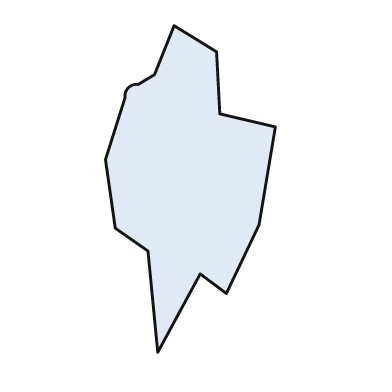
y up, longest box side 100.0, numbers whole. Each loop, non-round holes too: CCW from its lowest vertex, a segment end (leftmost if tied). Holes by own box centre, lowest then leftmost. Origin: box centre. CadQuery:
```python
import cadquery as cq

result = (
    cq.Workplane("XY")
    .moveTo(-10.0, -50.0)
    .lineTo(3.0, -26.0)
    .lineTo(11.0, -32.0)
    .lineTo(21.0, -11.0)
    .lineTo(26.0, 19.0)
    .lineTo(9.0, 23.0)
    .lineTo(8.0, 42.0)
    .lineTo(-5.0, 50.0)
    .lineTo(-11.0, 35.0)
    .lineTo(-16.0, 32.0)
    .threePointArc((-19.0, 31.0), (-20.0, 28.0))
    .lineTo(-26.0, 9.0)
    .lineTo(-23.0, -12.0)
    .lineTo(-13.0, -19.0)
    .close()
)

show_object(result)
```